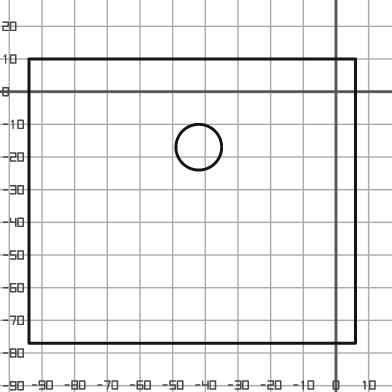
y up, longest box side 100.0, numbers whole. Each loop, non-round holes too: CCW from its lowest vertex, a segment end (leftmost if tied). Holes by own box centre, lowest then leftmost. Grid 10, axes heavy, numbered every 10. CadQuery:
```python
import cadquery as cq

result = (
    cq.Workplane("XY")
    .moveTo(-94.0, -77.0)
    .lineTo(6.0, -77.0)
    .lineTo(6.0, 10.0)
    .lineTo(-94.0, 10.0)
    .close()
    .moveTo(-42.0, -17.0)
    .circle(7.0)
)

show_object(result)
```